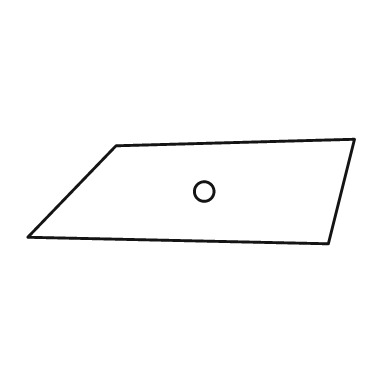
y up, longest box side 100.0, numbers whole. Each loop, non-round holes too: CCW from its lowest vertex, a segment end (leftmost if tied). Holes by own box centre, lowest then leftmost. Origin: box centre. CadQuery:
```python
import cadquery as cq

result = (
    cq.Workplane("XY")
    .moveTo(42.0, -16.0)
    .lineTo(50.0, 16.0)
    .lineTo(-23.0, 14.0)
    .lineTo(-50.0, -14.0)
    .close()
    .moveTo(4.0, 0.0)
    .circle(3.0)
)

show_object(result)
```